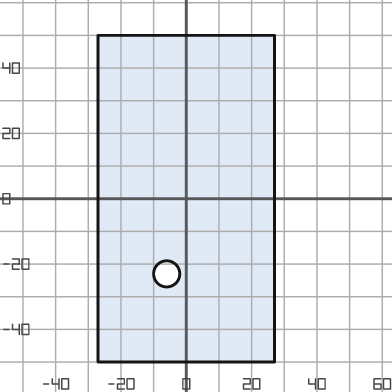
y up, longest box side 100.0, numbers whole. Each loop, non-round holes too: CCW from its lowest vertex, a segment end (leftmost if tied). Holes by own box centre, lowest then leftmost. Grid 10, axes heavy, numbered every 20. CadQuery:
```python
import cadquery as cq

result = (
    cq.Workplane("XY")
    .moveTo(-27.0, -50.0)
    .lineTo(27.0, -50.0)
    .lineTo(27.0, 50.0)
    .lineTo(-27.0, 50.0)
    .close()
    .moveTo(-6.0, -23.0)
    .circle(4.0)
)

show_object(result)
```